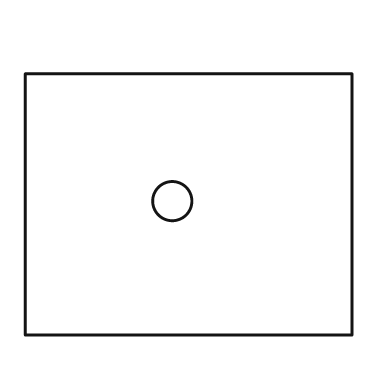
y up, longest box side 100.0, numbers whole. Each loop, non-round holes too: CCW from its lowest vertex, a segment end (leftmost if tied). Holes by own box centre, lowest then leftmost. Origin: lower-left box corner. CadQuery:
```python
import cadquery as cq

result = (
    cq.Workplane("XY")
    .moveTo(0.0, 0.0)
    .lineTo(100.0, 0.0)
    .lineTo(100.0, 80.0)
    .lineTo(0.0, 80.0)
    .close()
    .moveTo(45.0, 41.0)
    .circle(6.0)
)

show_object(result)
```